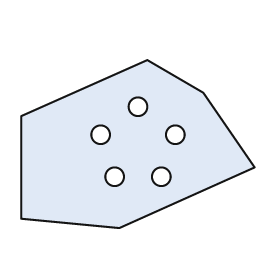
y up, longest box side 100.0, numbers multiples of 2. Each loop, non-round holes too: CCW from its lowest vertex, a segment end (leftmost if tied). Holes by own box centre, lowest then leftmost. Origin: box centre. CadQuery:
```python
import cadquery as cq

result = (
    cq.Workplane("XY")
    .moveTo(-8.0, -36.0)
    .lineTo(50.0, -10.0)
    .lineTo(28.0, 22.0)
    .lineTo(4.0, 36.0)
    .lineTo(-50.0, 12.0)
    .lineTo(-50.0, -32.0)
    .close()
    .moveTo(-10.0, -14.0)
    .circle(4.0)
    .moveTo(10.0, -14.0)
    .circle(4.0)
    .moveTo(-16.0, 4.0)
    .circle(4.0)
    .moveTo(16.0, 4.0)
    .circle(4.0)
    .moveTo(0.0, 16.0)
    .circle(4.0)
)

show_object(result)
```